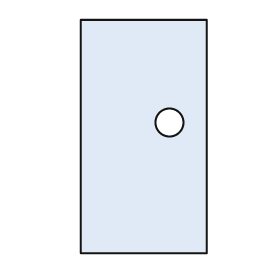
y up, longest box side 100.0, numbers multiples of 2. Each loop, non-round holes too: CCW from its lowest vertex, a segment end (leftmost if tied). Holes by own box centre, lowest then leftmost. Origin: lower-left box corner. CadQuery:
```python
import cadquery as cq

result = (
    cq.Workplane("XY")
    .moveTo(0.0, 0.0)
    .lineTo(54.0, 0.0)
    .lineTo(54.0, 100.0)
    .lineTo(0.0, 100.0)
    .close()
    .moveTo(38.0, 56.0)
    .circle(6.0)
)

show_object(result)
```